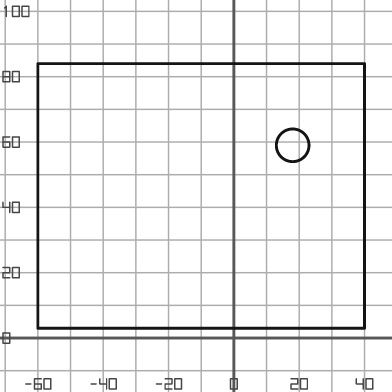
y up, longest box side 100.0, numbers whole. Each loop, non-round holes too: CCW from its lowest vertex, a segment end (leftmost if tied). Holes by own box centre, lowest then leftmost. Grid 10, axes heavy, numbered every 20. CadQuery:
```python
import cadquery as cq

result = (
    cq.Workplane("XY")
    .moveTo(-60.0, 3.0)
    .lineTo(40.0, 3.0)
    .lineTo(40.0, 84.0)
    .lineTo(-60.0, 84.0)
    .close()
    .moveTo(18.0, 59.0)
    .circle(5.0)
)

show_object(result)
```